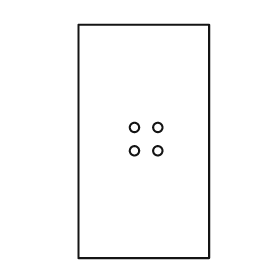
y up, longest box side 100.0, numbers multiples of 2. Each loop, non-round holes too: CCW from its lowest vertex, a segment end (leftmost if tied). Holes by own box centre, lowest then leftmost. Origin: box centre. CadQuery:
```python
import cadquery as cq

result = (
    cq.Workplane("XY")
    .moveTo(-28.0, -50.0)
    .lineTo(28.0, -50.0)
    .lineTo(28.0, 50.0)
    .lineTo(-28.0, 50.0)
    .close()
    .moveTo(-4.0, -4.0)
    .circle(2.0)
    .moveTo(6.0, -4.0)
    .circle(2.0)
    .moveTo(-4.0, 6.0)
    .circle(2.0)
    .moveTo(6.0, 6.0)
    .circle(2.0)
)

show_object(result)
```